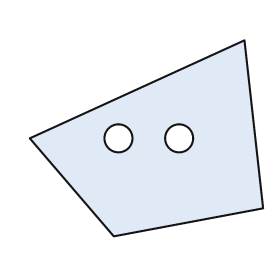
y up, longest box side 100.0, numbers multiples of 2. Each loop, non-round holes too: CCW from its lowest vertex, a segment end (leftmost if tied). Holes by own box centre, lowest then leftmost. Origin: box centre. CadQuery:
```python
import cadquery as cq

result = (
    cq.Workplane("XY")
    .moveTo(-14.0, -42.0)
    .lineTo(50.0, -30.0)
    .lineTo(42.0, 42.0)
    .lineTo(-50.0, 0.0)
    .close()
    .moveTo(-12.0, 0.0)
    .circle(6.0)
    .moveTo(14.0, 0.0)
    .circle(6.0)
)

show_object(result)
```